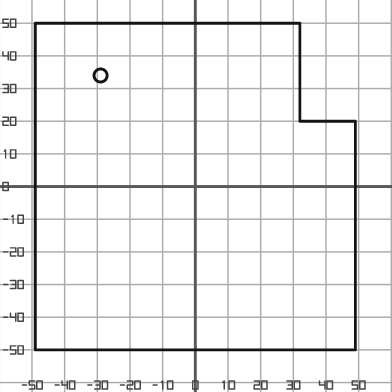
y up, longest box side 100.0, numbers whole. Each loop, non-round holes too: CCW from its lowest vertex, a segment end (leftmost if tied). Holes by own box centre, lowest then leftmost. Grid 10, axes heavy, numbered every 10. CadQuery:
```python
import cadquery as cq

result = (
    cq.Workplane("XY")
    .moveTo(-49.0, -50.0)
    .lineTo(49.0, -50.0)
    .lineTo(49.0, 20.0)
    .lineTo(32.0, 20.0)
    .lineTo(32.0, 50.0)
    .lineTo(-49.0, 50.0)
    .close()
    .moveTo(-29.0, 34.0)
    .circle(2.0)
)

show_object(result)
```